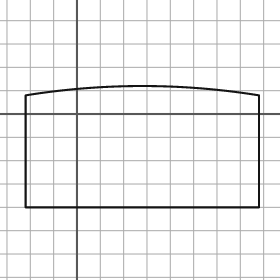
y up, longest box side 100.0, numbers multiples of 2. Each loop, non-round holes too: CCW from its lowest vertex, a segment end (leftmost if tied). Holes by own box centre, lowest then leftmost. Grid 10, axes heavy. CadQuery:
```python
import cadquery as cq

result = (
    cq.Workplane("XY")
    .moveTo(-22.0, -40.0)
    .lineTo(78.0, -40.0)
    .lineTo(78.0, 8.0)
    .threePointArc((28.0, 12.0), (-22.0, 8.0))
    .close()
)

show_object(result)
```